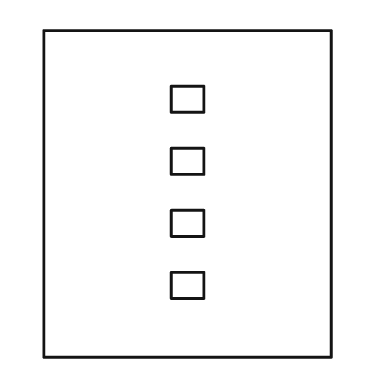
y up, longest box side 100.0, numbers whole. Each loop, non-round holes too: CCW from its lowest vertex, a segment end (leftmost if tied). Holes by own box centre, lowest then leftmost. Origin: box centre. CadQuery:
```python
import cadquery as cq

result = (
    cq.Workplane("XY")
    .moveTo(-44.0, -50.0)
    .lineTo(44.0, -50.0)
    .lineTo(44.0, 50.0)
    .lineTo(-44.0, 50.0)
    .close()
    .moveTo(-5.0, -32.0)
    .lineTo(5.0, -32.0)
    .lineTo(5.0, -24.0)
    .lineTo(-5.0, -24.0)
    .close()
    .moveTo(-5.0, -13.0)
    .lineTo(5.0, -13.0)
    .lineTo(5.0, -5.0)
    .lineTo(-5.0, -5.0)
    .close()
    .moveTo(-5.0, 6.0)
    .lineTo(5.0, 6.0)
    .lineTo(5.0, 14.0)
    .lineTo(-5.0, 14.0)
    .close()
    .moveTo(-5.0, 25.0)
    .lineTo(5.0, 25.0)
    .lineTo(5.0, 33.0)
    .lineTo(-5.0, 33.0)
    .close()
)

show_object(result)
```